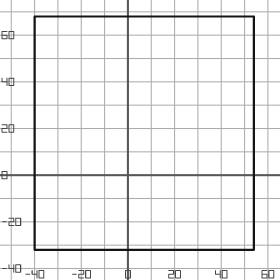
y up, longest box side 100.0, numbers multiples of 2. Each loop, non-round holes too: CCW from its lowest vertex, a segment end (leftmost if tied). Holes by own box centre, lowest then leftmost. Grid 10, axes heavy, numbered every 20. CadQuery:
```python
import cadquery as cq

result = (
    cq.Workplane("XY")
    .moveTo(-40.0, -32.0)
    .lineTo(54.0, -32.0)
    .lineTo(54.0, 68.0)
    .lineTo(-40.0, 68.0)
    .close()
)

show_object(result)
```